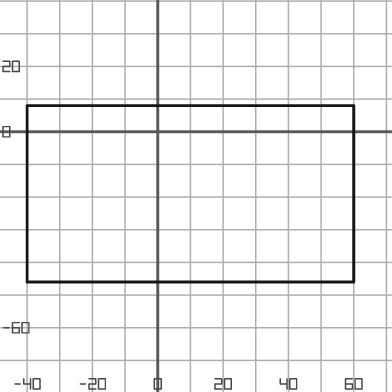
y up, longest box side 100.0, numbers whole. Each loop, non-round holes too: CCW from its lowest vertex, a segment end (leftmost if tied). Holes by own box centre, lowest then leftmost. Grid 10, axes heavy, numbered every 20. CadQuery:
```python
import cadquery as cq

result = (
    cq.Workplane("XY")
    .moveTo(-40.0, -46.0)
    .lineTo(60.0, -46.0)
    .lineTo(60.0, 8.0)
    .lineTo(-40.0, 8.0)
    .close()
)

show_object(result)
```